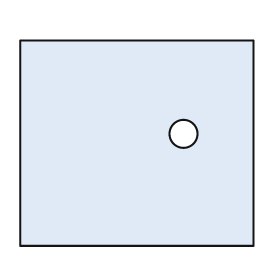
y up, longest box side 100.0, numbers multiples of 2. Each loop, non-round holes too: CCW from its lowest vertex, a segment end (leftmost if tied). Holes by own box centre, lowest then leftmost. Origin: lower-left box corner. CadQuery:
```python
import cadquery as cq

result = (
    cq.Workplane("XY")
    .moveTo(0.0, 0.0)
    .lineTo(100.0, 0.0)
    .lineTo(100.0, 88.0)
    .lineTo(0.0, 88.0)
    .close()
    .moveTo(70.0, 48.0)
    .circle(6.0)
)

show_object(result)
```